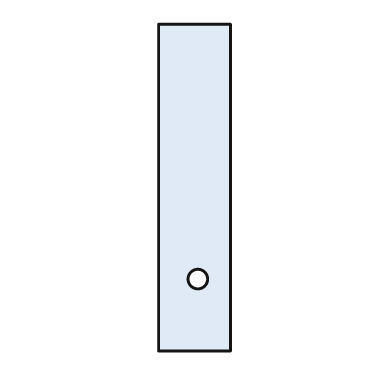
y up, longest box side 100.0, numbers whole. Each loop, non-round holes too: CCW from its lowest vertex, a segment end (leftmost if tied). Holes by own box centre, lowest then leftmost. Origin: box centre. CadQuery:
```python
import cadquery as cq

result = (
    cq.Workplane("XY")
    .moveTo(-11.0, -50.0)
    .lineTo(11.0, -50.0)
    .lineTo(11.0, 50.0)
    .lineTo(-11.0, 50.0)
    .close()
    .moveTo(1.0, -28.0)
    .circle(3.0)
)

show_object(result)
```